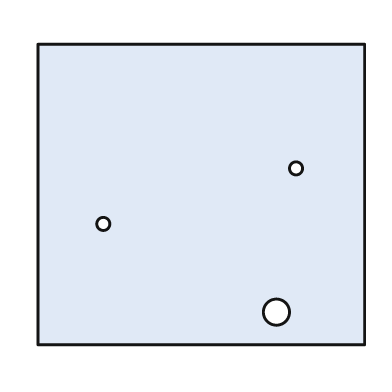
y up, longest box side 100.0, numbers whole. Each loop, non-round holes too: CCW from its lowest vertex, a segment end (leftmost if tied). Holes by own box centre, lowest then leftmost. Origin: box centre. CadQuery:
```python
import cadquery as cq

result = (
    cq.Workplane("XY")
    .moveTo(-50.0, -46.0)
    .lineTo(50.0, -46.0)
    .lineTo(50.0, 46.0)
    .lineTo(-50.0, 46.0)
    .close()
    .moveTo(23.0, -36.0)
    .circle(4.0)
    .moveTo(-30.0, -9.0)
    .circle(2.0)
    .moveTo(29.0, 8.0)
    .circle(2.0)
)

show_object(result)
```